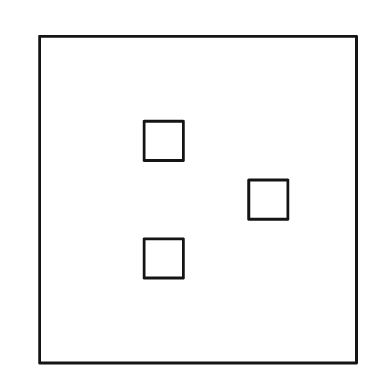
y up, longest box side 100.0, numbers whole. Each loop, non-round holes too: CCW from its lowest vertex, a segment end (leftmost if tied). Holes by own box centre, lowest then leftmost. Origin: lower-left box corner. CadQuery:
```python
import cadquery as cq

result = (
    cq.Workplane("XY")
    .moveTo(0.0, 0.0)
    .lineTo(97.0, 0.0)
    .lineTo(97.0, 100.0)
    .lineTo(0.0, 100.0)
    .close()
    .moveTo(32.0, 26.0)
    .lineTo(44.0, 26.0)
    .lineTo(44.0, 38.0)
    .lineTo(32.0, 38.0)
    .close()
    .moveTo(64.0, 44.0)
    .lineTo(76.0, 44.0)
    .lineTo(76.0, 56.0)
    .lineTo(64.0, 56.0)
    .close()
    .moveTo(32.0, 62.0)
    .lineTo(44.0, 62.0)
    .lineTo(44.0, 74.0)
    .lineTo(32.0, 74.0)
    .close()
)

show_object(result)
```